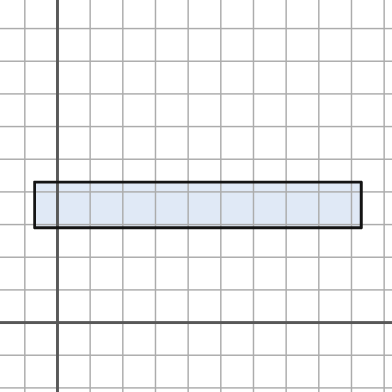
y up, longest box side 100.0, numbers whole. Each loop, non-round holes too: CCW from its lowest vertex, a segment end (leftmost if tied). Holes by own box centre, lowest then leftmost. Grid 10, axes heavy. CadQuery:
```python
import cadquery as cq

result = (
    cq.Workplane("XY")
    .moveTo(-7.0, 29.0)
    .lineTo(93.0, 29.0)
    .lineTo(93.0, 43.0)
    .lineTo(-7.0, 43.0)
    .close()
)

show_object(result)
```